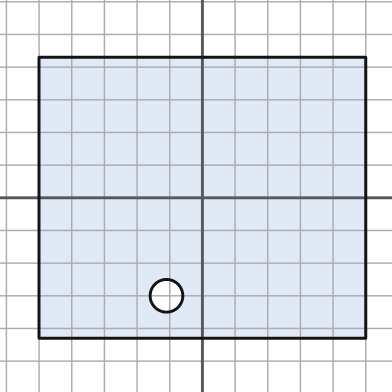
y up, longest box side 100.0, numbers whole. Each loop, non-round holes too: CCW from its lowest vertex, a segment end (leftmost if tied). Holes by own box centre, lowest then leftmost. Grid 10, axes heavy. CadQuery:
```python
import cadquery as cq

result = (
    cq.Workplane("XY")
    .moveTo(-50.0, -43.0)
    .lineTo(50.0, -43.0)
    .lineTo(50.0, 43.0)
    .lineTo(-50.0, 43.0)
    .close()
    .moveTo(-11.0, -30.0)
    .circle(5.0)
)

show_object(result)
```